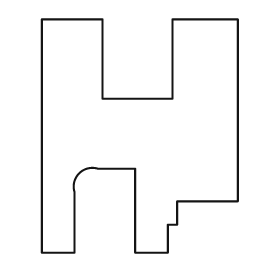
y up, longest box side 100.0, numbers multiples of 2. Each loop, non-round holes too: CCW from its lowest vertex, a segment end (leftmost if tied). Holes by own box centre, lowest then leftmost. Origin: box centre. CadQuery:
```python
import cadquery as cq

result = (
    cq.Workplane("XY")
    .moveTo(-42.0, -50.0)
    .lineTo(-28.0, -50.0)
    .lineTo(-28.0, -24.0)
    .threePointArc((-26.0, -16.0), (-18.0, -14.0))
    .lineTo(-2.0, -14.0)
    .lineTo(-2.0, -50.0)
    .lineTo(12.0, -50.0)
    .lineTo(12.0, -38.0)
    .lineTo(16.0, -38.0)
    .lineTo(16.0, -28.0)
    .lineTo(42.0, -28.0)
    .lineTo(42.0, 50.0)
    .lineTo(14.0, 50.0)
    .lineTo(14.0, 16.0)
    .lineTo(-16.0, 16.0)
    .lineTo(-16.0, 50.0)
    .lineTo(-42.0, 50.0)
    .close()
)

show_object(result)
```